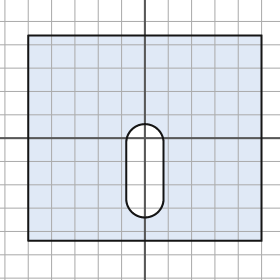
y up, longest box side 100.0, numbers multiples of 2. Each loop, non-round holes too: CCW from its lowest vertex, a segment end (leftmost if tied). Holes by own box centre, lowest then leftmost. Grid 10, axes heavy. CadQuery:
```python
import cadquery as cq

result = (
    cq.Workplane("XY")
    .moveTo(-50.0, -44.0)
    .lineTo(50.0, -44.0)
    .lineTo(50.0, 44.0)
    .lineTo(-50.0, 44.0)
    .close()
    .moveTo(-8.0, -26.0)
    .threePointArc((0.0, -34.0), (8.0, -26.0))
    .lineTo(8.0, -2.0)
    .threePointArc((0.0, 6.0), (-8.0, -2.0))
    .close()
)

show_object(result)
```